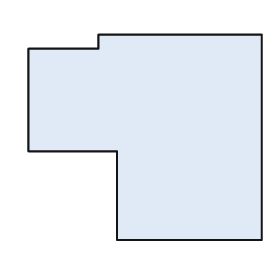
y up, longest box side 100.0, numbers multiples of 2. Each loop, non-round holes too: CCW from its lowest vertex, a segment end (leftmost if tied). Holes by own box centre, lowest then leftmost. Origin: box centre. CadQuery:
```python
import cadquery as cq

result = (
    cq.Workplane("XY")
    .moveTo(-12.0, -44.0)
    .lineTo(50.0, -44.0)
    .lineTo(50.0, 44.0)
    .lineTo(-20.0, 44.0)
    .lineTo(-20.0, 38.0)
    .lineTo(-50.0, 38.0)
    .lineTo(-50.0, -6.0)
    .lineTo(-12.0, -6.0)
    .close()
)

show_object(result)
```